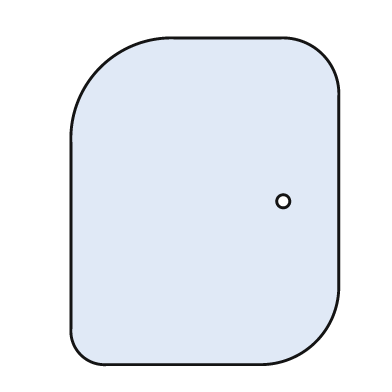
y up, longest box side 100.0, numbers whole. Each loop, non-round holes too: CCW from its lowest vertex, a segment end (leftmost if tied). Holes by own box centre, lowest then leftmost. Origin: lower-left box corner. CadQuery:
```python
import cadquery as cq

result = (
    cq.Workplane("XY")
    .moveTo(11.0, 0.0)
    .lineTo(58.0, 0.0)
    .threePointArc((75.0, 7.0), (82.0, 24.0))
    .lineTo(82.0, 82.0)
    .threePointArc((77.0, 95.0), (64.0, 100.0))
    .lineTo(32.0, 100.0)
    .threePointArc((9.0, 91.0), (0.0, 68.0))
    .lineTo(0.0, 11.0)
    .threePointArc((3.0, 3.0), (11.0, 0.0))
    .close()
    .moveTo(65.0, 50.0)
    .circle(2.0)
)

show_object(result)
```